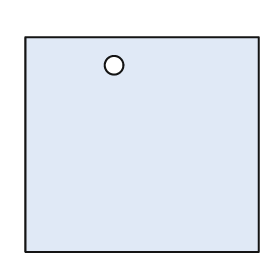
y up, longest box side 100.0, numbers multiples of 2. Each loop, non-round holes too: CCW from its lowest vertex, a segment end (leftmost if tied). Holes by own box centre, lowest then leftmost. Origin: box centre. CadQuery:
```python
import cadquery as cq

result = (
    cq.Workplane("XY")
    .moveTo(-50.0, -46.0)
    .lineTo(50.0, -46.0)
    .lineTo(50.0, 46.0)
    .lineTo(-50.0, 46.0)
    .close()
    .moveTo(-12.0, 34.0)
    .circle(4.0)
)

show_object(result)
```